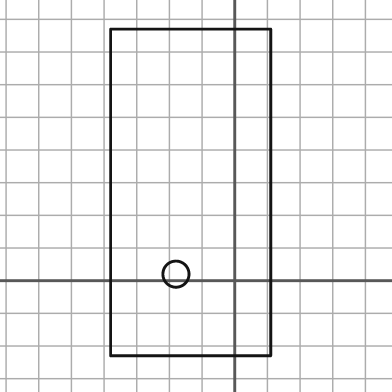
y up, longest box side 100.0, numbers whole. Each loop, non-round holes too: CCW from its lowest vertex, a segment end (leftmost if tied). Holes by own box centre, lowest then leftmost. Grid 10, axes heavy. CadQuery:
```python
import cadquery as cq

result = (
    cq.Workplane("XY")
    .moveTo(-38.0, -23.0)
    .lineTo(11.0, -23.0)
    .lineTo(11.0, 77.0)
    .lineTo(-38.0, 77.0)
    .close()
    .moveTo(-18.0, 2.0)
    .circle(4.0)
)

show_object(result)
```